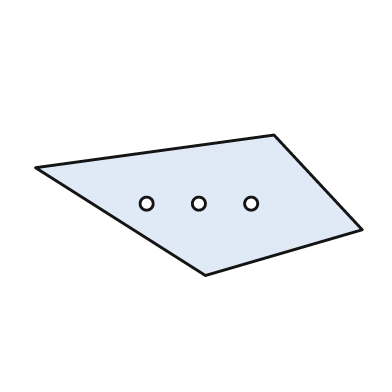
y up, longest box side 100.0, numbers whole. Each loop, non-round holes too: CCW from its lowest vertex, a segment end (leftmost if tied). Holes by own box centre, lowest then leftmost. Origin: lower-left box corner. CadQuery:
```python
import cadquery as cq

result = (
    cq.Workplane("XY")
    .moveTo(52.0, 0.0)
    .lineTo(100.0, 14.0)
    .lineTo(73.0, 43.0)
    .lineTo(0.0, 33.0)
    .close()
    .moveTo(34.0, 22.0)
    .circle(2.0)
    .moveTo(50.0, 22.0)
    .circle(2.0)
    .moveTo(66.0, 22.0)
    .circle(2.0)
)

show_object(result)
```